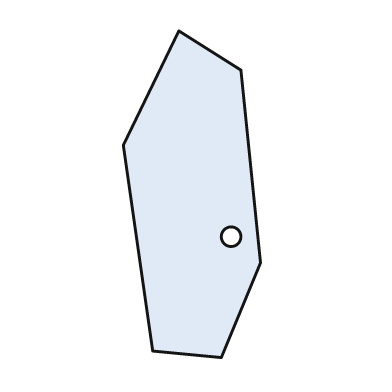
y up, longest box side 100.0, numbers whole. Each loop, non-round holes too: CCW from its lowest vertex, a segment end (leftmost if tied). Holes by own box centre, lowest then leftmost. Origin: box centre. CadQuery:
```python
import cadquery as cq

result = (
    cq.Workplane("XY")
    .moveTo(9.0, -50.0)
    .lineTo(21.0, -21.0)
    .lineTo(15.0, 38.0)
    .lineTo(-4.0, 50.0)
    .lineTo(-21.0, 15.0)
    .lineTo(-12.0, -48.0)
    .close()
    .moveTo(12.0, -13.0)
    .circle(3.0)
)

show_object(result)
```